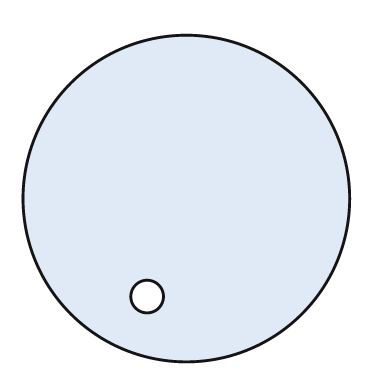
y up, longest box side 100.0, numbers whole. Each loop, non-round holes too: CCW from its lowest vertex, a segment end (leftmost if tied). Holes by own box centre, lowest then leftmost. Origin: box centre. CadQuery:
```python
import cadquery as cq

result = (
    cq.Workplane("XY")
    .moveTo(0.0, 0.0)
    .circle(50.0)
    .moveTo(-12.0, -30.0)
    .circle(5.0)
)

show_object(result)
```